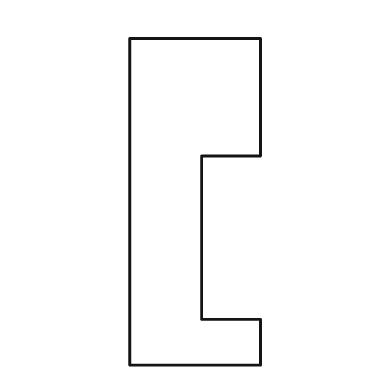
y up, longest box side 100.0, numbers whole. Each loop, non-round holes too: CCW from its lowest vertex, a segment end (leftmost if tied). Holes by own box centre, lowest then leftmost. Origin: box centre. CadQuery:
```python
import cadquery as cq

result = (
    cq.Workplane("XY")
    .moveTo(-20.0, -50.0)
    .lineTo(20.0, -50.0)
    .lineTo(20.0, -36.0)
    .lineTo(2.0, -36.0)
    .lineTo(2.0, 14.0)
    .lineTo(20.0, 14.0)
    .lineTo(20.0, 50.0)
    .lineTo(-20.0, 50.0)
    .close()
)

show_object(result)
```